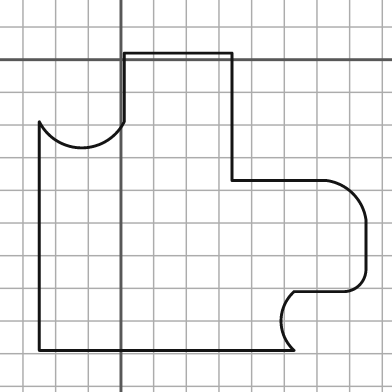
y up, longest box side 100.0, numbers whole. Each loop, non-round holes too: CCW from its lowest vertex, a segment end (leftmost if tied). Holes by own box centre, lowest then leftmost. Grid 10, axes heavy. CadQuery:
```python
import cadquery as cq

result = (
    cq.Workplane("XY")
    .moveTo(-25.0, -89.0)
    .lineTo(53.0, -89.0)
    .threePointArc((49.0, -80.0), (53.0, -71.0))
    .lineTo(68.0, -71.0)
    .threePointArc((73.0, -69.0), (75.0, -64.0))
    .lineTo(75.0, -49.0)
    .threePointArc((71.0, -41.0), (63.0, -37.0))
    .lineTo(34.0, -37.0)
    .lineTo(34.0, 2.0)
    .lineTo(1.0, 2.0)
    .lineTo(1.0, -19.0)
    .threePointArc((-12.0, -27.0), (-25.0, -19.0))
    .close()
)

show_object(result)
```